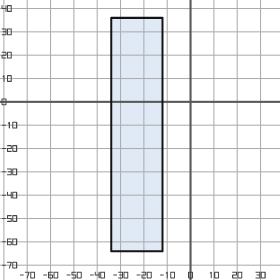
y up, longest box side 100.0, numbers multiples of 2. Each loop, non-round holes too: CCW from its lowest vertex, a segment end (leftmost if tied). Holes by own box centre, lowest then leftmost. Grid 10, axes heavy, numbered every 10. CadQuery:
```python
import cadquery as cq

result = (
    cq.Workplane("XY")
    .moveTo(-34.0, -64.0)
    .lineTo(-12.0, -64.0)
    .lineTo(-12.0, 36.0)
    .lineTo(-34.0, 36.0)
    .close()
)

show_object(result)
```